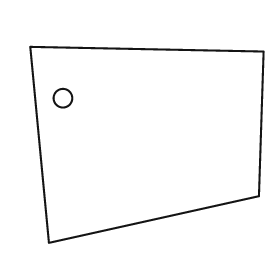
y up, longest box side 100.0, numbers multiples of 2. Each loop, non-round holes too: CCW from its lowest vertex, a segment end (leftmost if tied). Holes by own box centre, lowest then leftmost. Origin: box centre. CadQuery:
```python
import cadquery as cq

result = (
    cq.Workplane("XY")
    .moveTo(-42.0, -42.0)
    .lineTo(48.0, -22.0)
    .lineTo(50.0, 40.0)
    .lineTo(-50.0, 42.0)
    .close()
    .moveTo(-36.0, 20.0)
    .circle(4.0)
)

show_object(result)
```